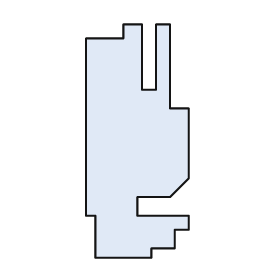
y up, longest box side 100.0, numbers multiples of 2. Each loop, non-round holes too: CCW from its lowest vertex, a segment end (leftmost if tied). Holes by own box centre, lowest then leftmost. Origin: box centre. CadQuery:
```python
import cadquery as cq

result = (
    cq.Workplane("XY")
    .moveTo(-18.0, -50.0)
    .lineTo(6.0, -50.0)
    .lineTo(6.0, -46.0)
    .lineTo(16.0, -46.0)
    .lineTo(16.0, -38.0)
    .lineTo(22.0, -38.0)
    .lineTo(22.0, -32.0)
    .lineTo(0.0, -32.0)
    .lineTo(0.0, -24.0)
    .lineTo(14.0, -24.0)
    .lineTo(22.0, -16.0)
    .lineTo(22.0, 14.0)
    .lineTo(14.0, 14.0)
    .lineTo(14.0, 50.0)
    .lineTo(8.0, 50.0)
    .lineTo(8.0, 22.0)
    .lineTo(2.0, 22.0)
    .lineTo(2.0, 50.0)
    .lineTo(-6.0, 50.0)
    .lineTo(-6.0, 44.0)
    .lineTo(-22.0, 44.0)
    .lineTo(-22.0, -32.0)
    .lineTo(-18.0, -32.0)
    .close()
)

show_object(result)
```